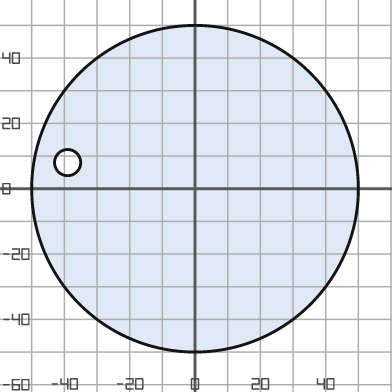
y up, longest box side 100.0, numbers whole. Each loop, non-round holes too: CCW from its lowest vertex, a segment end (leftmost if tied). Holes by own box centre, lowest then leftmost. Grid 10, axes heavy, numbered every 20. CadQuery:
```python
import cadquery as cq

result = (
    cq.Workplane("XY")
    .moveTo(0.0, 0.0)
    .circle(50.0)
    .moveTo(-39.0, 8.0)
    .circle(4.0)
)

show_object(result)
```